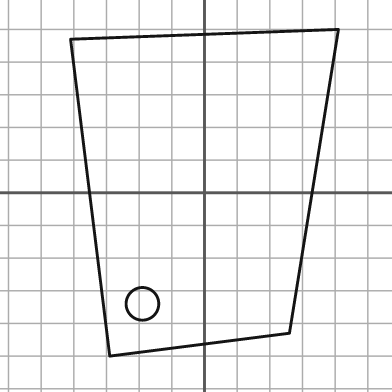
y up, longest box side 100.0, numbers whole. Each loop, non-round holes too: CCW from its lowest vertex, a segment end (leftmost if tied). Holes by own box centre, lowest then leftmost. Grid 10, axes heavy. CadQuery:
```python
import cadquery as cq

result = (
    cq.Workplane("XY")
    .moveTo(-29.0, -50.0)
    .lineTo(26.0, -43.0)
    .lineTo(41.0, 50.0)
    .lineTo(-41.0, 47.0)
    .close()
    .moveTo(-19.0, -34.0)
    .circle(5.0)
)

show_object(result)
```